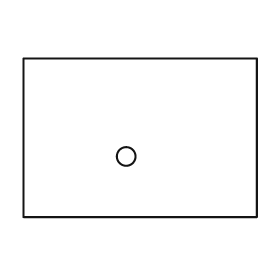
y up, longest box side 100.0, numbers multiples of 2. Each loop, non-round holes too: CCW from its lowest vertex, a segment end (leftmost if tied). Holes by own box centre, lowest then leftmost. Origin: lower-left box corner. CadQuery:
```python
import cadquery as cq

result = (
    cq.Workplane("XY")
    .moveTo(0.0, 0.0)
    .lineTo(100.0, 0.0)
    .lineTo(100.0, 68.0)
    .lineTo(0.0, 68.0)
    .close()
    .moveTo(44.0, 26.0)
    .circle(4.0)
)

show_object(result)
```